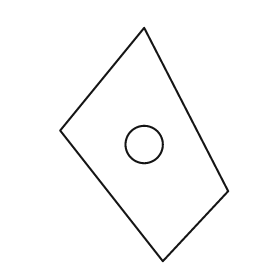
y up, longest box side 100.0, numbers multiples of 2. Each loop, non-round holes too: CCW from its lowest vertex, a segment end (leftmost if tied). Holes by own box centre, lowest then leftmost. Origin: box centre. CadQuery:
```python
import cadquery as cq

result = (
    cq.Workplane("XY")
    .moveTo(8.0, -50.0)
    .lineTo(36.0, -20.0)
    .lineTo(0.0, 50.0)
    .lineTo(-36.0, 6.0)
    .close()
    .moveTo(0.0, 0.0)
    .circle(8.0)
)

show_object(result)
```